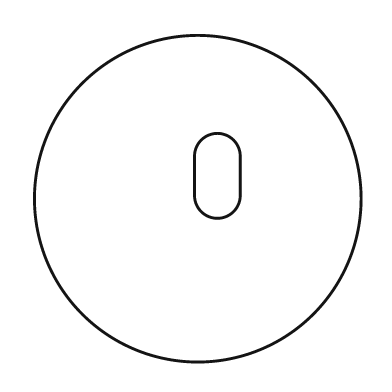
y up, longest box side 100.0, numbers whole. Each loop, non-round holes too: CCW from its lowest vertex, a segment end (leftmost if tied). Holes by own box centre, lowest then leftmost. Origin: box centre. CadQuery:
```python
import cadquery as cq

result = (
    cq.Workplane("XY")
    .moveTo(0.0, 0.0)
    .circle(50.0)
    .moveTo(-1.0, 1.0)
    .threePointArc((6.0, -6.0), (13.0, 1.0))
    .lineTo(13.0, 13.0)
    .threePointArc((6.0, 20.0), (-1.0, 13.0))
    .close()
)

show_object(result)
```